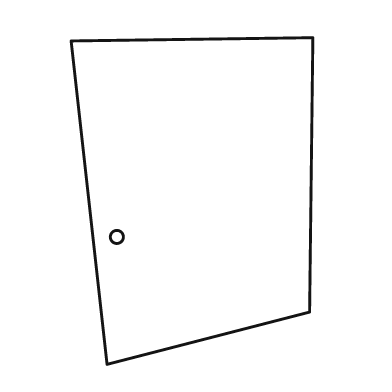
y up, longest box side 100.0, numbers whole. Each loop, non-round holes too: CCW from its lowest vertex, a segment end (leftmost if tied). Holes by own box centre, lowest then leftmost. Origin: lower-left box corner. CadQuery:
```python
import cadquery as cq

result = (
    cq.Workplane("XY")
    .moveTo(11.0, 0.0)
    .lineTo(73.0, 16.0)
    .lineTo(74.0, 100.0)
    .lineTo(0.0, 99.0)
    .close()
    .moveTo(14.0, 39.0)
    .circle(2.0)
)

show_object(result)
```